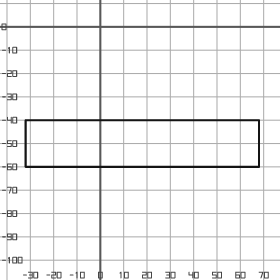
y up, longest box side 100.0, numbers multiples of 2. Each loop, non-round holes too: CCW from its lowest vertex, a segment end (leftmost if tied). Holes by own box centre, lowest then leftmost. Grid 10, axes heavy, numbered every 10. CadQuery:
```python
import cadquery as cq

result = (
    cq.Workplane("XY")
    .moveTo(-32.0, -60.0)
    .lineTo(68.0, -60.0)
    .lineTo(68.0, -40.0)
    .lineTo(-32.0, -40.0)
    .close()
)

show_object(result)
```